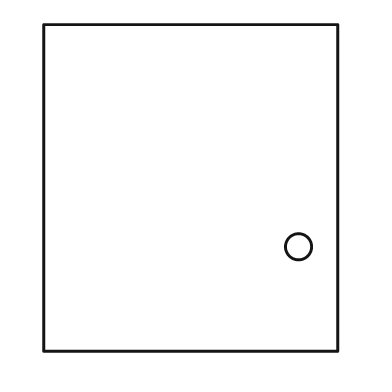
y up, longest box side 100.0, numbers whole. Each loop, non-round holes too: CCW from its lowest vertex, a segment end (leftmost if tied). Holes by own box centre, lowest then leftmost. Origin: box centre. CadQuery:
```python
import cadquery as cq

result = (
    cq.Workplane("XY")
    .moveTo(-45.0, -50.0)
    .lineTo(45.0, -50.0)
    .lineTo(45.0, 50.0)
    .lineTo(-45.0, 50.0)
    .close()
    .moveTo(33.0, -18.0)
    .circle(4.0)
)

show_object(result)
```